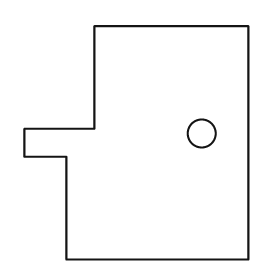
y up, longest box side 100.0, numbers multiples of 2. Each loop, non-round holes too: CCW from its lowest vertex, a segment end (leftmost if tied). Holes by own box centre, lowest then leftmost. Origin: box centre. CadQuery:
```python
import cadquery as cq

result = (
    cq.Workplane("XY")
    .moveTo(-30.0, -50.0)
    .lineTo(48.0, -50.0)
    .lineTo(48.0, 50.0)
    .lineTo(-18.0, 50.0)
    .lineTo(-18.0, 6.0)
    .lineTo(-48.0, 6.0)
    .lineTo(-48.0, -6.0)
    .lineTo(-30.0, -6.0)
    .close()
    .moveTo(28.0, 4.0)
    .circle(6.0)
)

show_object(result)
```